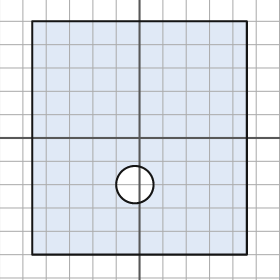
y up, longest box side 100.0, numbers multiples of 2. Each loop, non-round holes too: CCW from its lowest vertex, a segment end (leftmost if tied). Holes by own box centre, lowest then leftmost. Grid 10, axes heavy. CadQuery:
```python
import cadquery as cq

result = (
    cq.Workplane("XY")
    .moveTo(-46.0, -50.0)
    .lineTo(46.0, -50.0)
    .lineTo(46.0, 50.0)
    .lineTo(-46.0, 50.0)
    .close()
    .moveTo(-2.0, -20.0)
    .circle(8.0)
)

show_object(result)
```